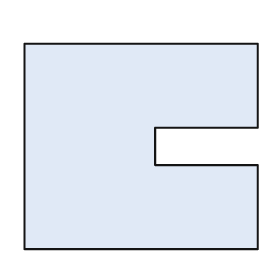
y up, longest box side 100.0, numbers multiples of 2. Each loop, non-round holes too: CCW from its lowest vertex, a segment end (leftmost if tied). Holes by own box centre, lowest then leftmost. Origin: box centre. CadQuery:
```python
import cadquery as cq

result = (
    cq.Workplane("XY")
    .moveTo(-50.0, -44.0)
    .lineTo(50.0, -44.0)
    .lineTo(50.0, -8.0)
    .lineTo(6.0, -8.0)
    .lineTo(6.0, 8.0)
    .lineTo(50.0, 8.0)
    .lineTo(50.0, 44.0)
    .lineTo(-50.0, 44.0)
    .close()
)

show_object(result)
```